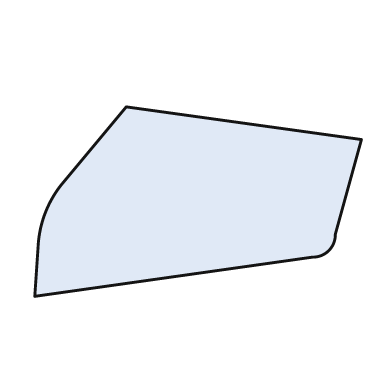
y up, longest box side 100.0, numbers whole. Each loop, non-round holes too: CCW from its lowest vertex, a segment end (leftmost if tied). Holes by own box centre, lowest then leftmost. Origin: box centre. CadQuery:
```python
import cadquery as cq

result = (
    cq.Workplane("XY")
    .moveTo(-50.0, -29.0)
    .lineTo(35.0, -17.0)
    .threePointArc((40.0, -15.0), (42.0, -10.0))
    .lineTo(50.0, 19.0)
    .lineTo(-22.0, 29.0)
    .lineTo(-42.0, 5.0)
    .threePointArc((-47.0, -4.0), (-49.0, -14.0))
    .close()
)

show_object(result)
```